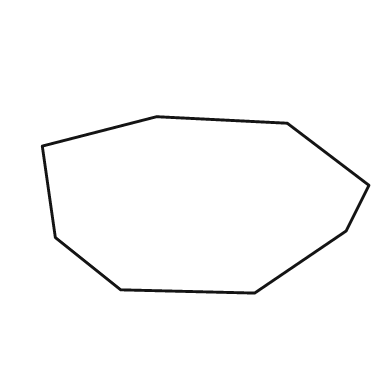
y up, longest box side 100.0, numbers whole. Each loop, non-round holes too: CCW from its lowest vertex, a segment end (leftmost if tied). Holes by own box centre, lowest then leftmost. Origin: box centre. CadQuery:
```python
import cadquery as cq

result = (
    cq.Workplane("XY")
    .moveTo(15.0, -27.0)
    .lineTo(43.0, -8.0)
    .lineTo(50.0, 6.0)
    .lineTo(25.0, 25.0)
    .lineTo(-15.0, 27.0)
    .lineTo(-50.0, 18.0)
    .lineTo(-46.0, -10.0)
    .lineTo(-26.0, -26.0)
    .close()
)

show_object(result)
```